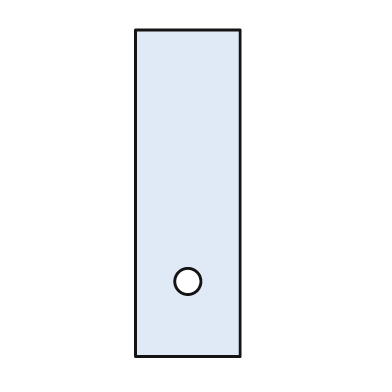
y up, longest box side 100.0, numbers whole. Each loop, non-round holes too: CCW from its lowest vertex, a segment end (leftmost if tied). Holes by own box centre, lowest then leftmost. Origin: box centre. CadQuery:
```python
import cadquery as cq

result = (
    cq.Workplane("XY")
    .moveTo(-16.0, -50.0)
    .lineTo(16.0, -50.0)
    .lineTo(16.0, 50.0)
    .lineTo(-16.0, 50.0)
    .close()
    .moveTo(0.0, -27.0)
    .circle(4.0)
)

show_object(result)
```